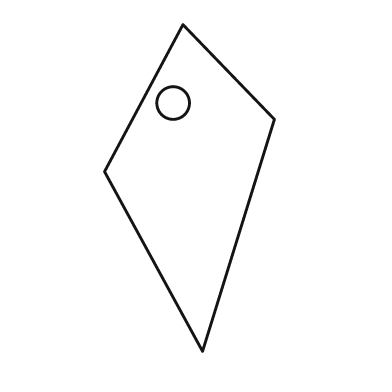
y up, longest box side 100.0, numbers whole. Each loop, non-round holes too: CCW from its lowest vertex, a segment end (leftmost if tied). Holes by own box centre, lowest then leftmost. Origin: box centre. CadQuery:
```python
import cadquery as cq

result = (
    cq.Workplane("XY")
    .moveTo(4.0, -50.0)
    .lineTo(26.0, 21.0)
    .lineTo(-2.0, 50.0)
    .lineTo(-26.0, 5.0)
    .close()
    .moveTo(-5.0, 26.0)
    .circle(5.0)
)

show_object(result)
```